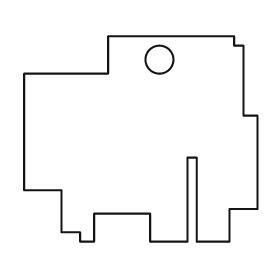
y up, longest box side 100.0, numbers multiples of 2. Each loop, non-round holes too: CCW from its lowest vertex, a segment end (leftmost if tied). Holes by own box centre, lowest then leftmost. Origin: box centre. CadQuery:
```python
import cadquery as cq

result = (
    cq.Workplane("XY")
    .moveTo(-26.0, -44.0)
    .lineTo(-20.0, -44.0)
    .lineTo(-20.0, -32.0)
    .lineTo(4.0, -32.0)
    .lineTo(4.0, -44.0)
    .lineTo(20.0, -44.0)
    .lineTo(20.0, -8.0)
    .lineTo(24.0, -8.0)
    .lineTo(24.0, -44.0)
    .lineTo(38.0, -44.0)
    .lineTo(38.0, -30.0)
    .lineTo(50.0, -30.0)
    .lineTo(50.0, 10.0)
    .lineTo(44.0, 10.0)
    .lineTo(44.0, 40.0)
    .lineTo(40.0, 40.0)
    .lineTo(40.0, 44.0)
    .lineTo(-14.0, 44.0)
    .lineTo(-14.0, 28.0)
    .lineTo(-50.0, 28.0)
    .lineTo(-50.0, -22.0)
    .lineTo(-34.0, -22.0)
    .lineTo(-34.0, -40.0)
    .lineTo(-26.0, -40.0)
    .close()
    .moveTo(8.0, 34.0)
    .circle(6.0)
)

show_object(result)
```